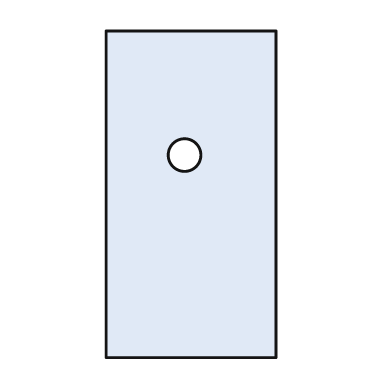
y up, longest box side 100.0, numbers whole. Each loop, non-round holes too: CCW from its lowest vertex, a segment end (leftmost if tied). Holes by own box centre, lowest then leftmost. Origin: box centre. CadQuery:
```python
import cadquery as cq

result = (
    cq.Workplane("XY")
    .moveTo(-26.0, -50.0)
    .lineTo(26.0, -50.0)
    .lineTo(26.0, 50.0)
    .lineTo(-26.0, 50.0)
    .close()
    .moveTo(-2.0, 12.0)
    .circle(5.0)
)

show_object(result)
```